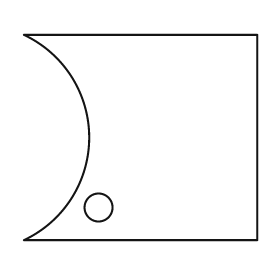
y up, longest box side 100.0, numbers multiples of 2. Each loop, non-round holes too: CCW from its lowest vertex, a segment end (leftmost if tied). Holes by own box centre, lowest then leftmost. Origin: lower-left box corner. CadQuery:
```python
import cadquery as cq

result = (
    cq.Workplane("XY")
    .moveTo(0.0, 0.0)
    .lineTo(100.0, 0.0)
    .lineTo(100.0, 88.0)
    .lineTo(0.0, 88.0)
    .threePointArc((28.0, 44.0), (0.0, 0.0))
    .close()
    .moveTo(32.0, 14.0)
    .circle(6.0)
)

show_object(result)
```